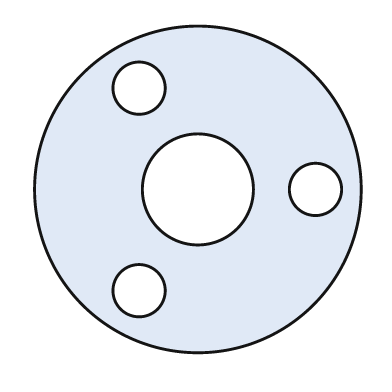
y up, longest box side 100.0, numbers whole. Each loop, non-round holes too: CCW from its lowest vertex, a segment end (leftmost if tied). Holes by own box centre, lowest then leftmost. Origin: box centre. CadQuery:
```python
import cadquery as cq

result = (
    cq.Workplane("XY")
    .moveTo(0.0, 0.0)
    .circle(50.0)
    .moveTo(-18.0, -31.0)
    .circle(8.0)
    .moveTo(0.0, 0.0)
    .circle(17.0)
    .moveTo(36.0, 0.0)
    .circle(8.0)
    .moveTo(-18.0, 31.0)
    .circle(8.0)
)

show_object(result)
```